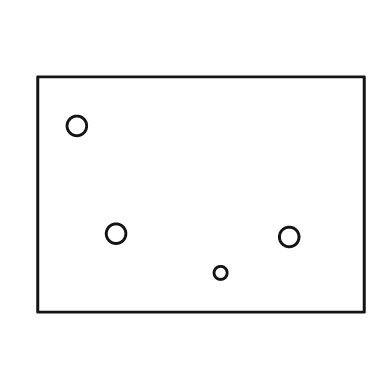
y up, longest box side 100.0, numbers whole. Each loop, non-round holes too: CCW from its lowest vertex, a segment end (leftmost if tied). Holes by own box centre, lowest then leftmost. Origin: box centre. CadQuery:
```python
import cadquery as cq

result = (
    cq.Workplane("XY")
    .moveTo(-50.0, -36.0)
    .lineTo(50.0, -36.0)
    .lineTo(50.0, 36.0)
    .lineTo(-50.0, 36.0)
    .close()
    .moveTo(6.0, -24.0)
    .circle(2.0)
    .moveTo(27.0, -13.0)
    .circle(3.0)
    .moveTo(-26.0, -12.0)
    .circle(3.0)
    .moveTo(-38.0, 21.0)
    .circle(3.0)
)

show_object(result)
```